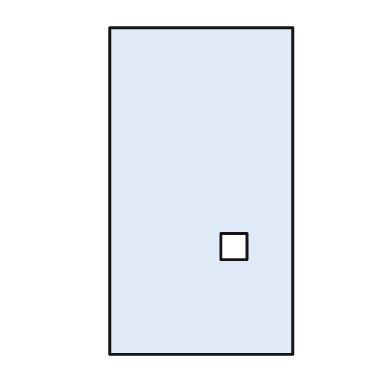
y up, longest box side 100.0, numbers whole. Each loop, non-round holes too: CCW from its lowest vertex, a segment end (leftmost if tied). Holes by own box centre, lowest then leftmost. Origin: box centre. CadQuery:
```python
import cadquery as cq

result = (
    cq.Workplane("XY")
    .moveTo(-28.0, -50.0)
    .lineTo(28.0, -50.0)
    .lineTo(28.0, 50.0)
    .lineTo(-28.0, 50.0)
    .close()
    .moveTo(6.0, -21.0)
    .lineTo(14.0, -21.0)
    .lineTo(14.0, -13.0)
    .lineTo(6.0, -13.0)
    .close()
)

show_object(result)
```